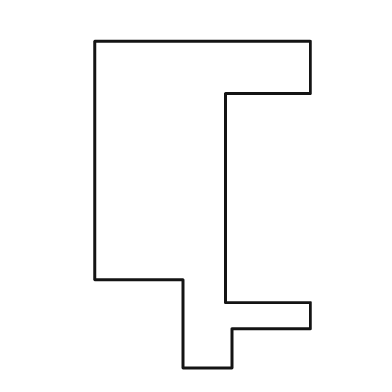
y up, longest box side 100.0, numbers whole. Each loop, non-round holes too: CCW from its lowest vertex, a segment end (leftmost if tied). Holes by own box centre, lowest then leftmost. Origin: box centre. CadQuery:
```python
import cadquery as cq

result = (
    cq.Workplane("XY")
    .moveTo(-6.0, -50.0)
    .lineTo(9.0, -50.0)
    .lineTo(9.0, -38.0)
    .lineTo(33.0, -38.0)
    .lineTo(33.0, -30.0)
    .lineTo(7.0, -30.0)
    .lineTo(7.0, 34.0)
    .lineTo(33.0, 34.0)
    .lineTo(33.0, 50.0)
    .lineTo(-33.0, 50.0)
    .lineTo(-33.0, -23.0)
    .lineTo(-6.0, -23.0)
    .close()
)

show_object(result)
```